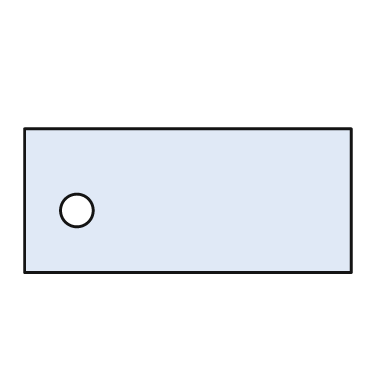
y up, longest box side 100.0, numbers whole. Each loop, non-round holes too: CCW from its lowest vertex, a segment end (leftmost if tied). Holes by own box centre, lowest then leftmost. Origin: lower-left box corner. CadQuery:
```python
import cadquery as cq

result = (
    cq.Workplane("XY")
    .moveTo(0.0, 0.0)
    .lineTo(100.0, 0.0)
    .lineTo(100.0, 44.0)
    .lineTo(0.0, 44.0)
    .close()
    .moveTo(16.0, 19.0)
    .circle(5.0)
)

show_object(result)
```